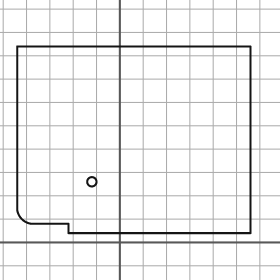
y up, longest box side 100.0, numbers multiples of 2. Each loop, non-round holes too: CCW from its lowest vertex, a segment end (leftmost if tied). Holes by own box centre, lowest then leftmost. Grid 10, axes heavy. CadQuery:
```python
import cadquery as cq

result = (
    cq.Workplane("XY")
    .moveTo(-22.0, 4.0)
    .lineTo(56.0, 4.0)
    .lineTo(56.0, 84.0)
    .lineTo(-44.0, 84.0)
    .lineTo(-44.0, 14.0)
    .threePointArc((-42.0, 10.0), (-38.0, 8.0))
    .lineTo(-22.0, 8.0)
    .close()
    .moveTo(-12.0, 26.0)
    .circle(2.0)
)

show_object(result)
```